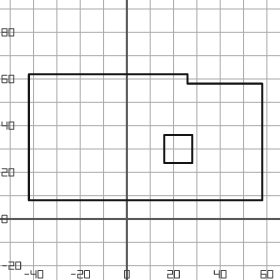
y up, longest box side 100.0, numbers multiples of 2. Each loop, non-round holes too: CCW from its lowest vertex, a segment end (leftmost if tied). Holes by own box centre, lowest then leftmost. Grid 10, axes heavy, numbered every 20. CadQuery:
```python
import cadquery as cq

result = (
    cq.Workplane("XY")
    .moveTo(-42.0, 8.0)
    .lineTo(58.0, 8.0)
    .lineTo(58.0, 58.0)
    .lineTo(26.0, 58.0)
    .lineTo(26.0, 62.0)
    .lineTo(-42.0, 62.0)
    .close()
    .moveTo(16.0, 24.0)
    .lineTo(28.0, 24.0)
    .lineTo(28.0, 36.0)
    .lineTo(16.0, 36.0)
    .close()
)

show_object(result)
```